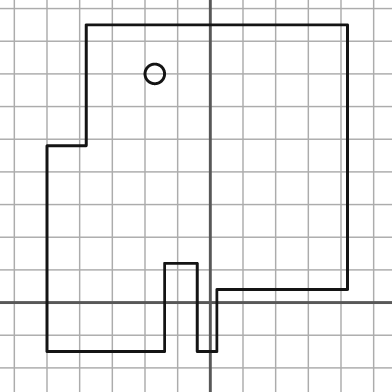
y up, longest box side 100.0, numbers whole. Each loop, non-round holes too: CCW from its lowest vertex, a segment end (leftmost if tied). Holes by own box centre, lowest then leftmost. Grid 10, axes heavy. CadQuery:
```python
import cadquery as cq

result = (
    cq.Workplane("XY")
    .moveTo(-50.0, -15.0)
    .lineTo(-14.0, -15.0)
    .lineTo(-14.0, 12.0)
    .lineTo(-4.0, 12.0)
    .lineTo(-4.0, -15.0)
    .lineTo(2.0, -15.0)
    .lineTo(2.0, 4.0)
    .lineTo(42.0, 4.0)
    .lineTo(42.0, 85.0)
    .lineTo(-38.0, 85.0)
    .lineTo(-38.0, 48.0)
    .lineTo(-50.0, 48.0)
    .close()
    .moveTo(-17.0, 70.0)
    .circle(3.0)
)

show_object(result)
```